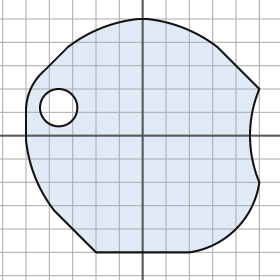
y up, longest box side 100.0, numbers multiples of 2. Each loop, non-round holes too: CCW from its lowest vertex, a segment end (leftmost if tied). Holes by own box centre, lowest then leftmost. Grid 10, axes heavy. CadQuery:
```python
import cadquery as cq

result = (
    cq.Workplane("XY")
    .moveTo(-20.0, -50.0)
    .lineTo(20.0, -50.0)
    .threePointArc((40.0, -40.0), (50.0, -20.0))
    .threePointArc((46.0, 0.0), (50.0, 20.0))
    .lineTo(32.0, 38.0)
    .threePointArc((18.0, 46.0), (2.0, 50.0))
    .lineTo(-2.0, 50.0)
    .threePointArc((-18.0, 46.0), (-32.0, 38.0))
    .lineTo(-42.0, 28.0)
    .threePointArc((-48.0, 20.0), (-50.0, 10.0))
    .lineTo(-50.0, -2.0)
    .threePointArc((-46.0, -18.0), (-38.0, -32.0))
    .close()
    .moveTo(-36.0, 12.0)
    .circle(8.0)
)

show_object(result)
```